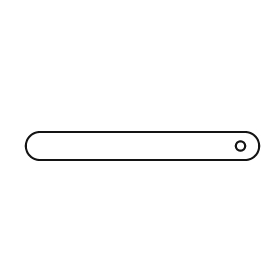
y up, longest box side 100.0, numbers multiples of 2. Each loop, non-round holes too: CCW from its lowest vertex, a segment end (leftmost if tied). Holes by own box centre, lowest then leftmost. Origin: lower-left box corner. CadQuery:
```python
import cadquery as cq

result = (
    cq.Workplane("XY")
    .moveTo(6.0, 0.0)
    .lineTo(94.0, 0.0)
    .threePointArc((100.0, 6.0), (94.0, 12.0))
    .lineTo(6.0, 12.0)
    .threePointArc((0.0, 6.0), (6.0, 0.0))
    .close()
    .moveTo(92.0, 6.0)
    .circle(2.0)
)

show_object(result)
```